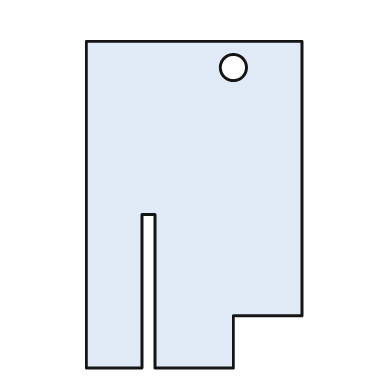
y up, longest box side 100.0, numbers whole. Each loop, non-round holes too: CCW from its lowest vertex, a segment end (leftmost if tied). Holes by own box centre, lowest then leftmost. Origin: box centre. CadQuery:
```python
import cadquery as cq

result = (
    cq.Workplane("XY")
    .moveTo(-33.0, -50.0)
    .lineTo(-16.0, -50.0)
    .lineTo(-16.0, -3.0)
    .lineTo(-12.0, -3.0)
    .lineTo(-12.0, -50.0)
    .lineTo(12.0, -50.0)
    .lineTo(12.0, -34.0)
    .lineTo(33.0, -34.0)
    .lineTo(33.0, 50.0)
    .lineTo(-33.0, 50.0)
    .close()
    .moveTo(12.0, 42.0)
    .circle(4.0)
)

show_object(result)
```